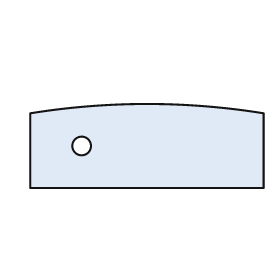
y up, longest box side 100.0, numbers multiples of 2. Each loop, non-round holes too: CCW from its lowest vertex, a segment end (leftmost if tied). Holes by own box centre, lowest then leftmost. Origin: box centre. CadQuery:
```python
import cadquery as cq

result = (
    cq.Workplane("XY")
    .moveTo(-50.0, -18.0)
    .lineTo(50.0, -18.0)
    .lineTo(50.0, 14.0)
    .threePointArc((0.0, 18.0), (-50.0, 14.0))
    .close()
    .moveTo(-28.0, 0.0)
    .circle(4.0)
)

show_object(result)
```